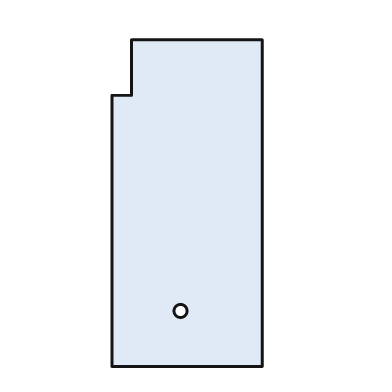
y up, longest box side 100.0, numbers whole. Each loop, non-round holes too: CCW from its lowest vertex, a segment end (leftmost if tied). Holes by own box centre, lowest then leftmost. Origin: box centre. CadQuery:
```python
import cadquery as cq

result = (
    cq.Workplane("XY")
    .moveTo(-23.0, -50.0)
    .lineTo(23.0, -50.0)
    .lineTo(23.0, 50.0)
    .lineTo(-17.0, 50.0)
    .lineTo(-17.0, 33.0)
    .lineTo(-23.0, 33.0)
    .close()
    .moveTo(-2.0, -33.0)
    .circle(2.0)
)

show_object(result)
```